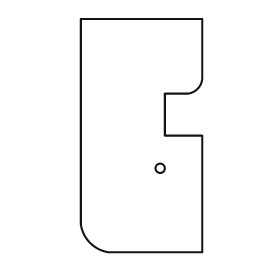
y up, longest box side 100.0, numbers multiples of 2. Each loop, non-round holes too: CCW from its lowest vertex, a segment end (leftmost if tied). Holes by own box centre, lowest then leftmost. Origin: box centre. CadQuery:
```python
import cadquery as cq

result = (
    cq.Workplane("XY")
    .moveTo(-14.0, -50.0)
    .lineTo(26.0, -50.0)
    .lineTo(26.0, 0.0)
    .lineTo(10.0, 0.0)
    .lineTo(10.0, 18.0)
    .lineTo(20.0, 18.0)
    .threePointArc((24.0, 20.0), (26.0, 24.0))
    .lineTo(26.0, 50.0)
    .lineTo(-26.0, 50.0)
    .lineTo(-26.0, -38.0)
    .threePointArc((-22.0, -46.0), (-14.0, -50.0))
    .close()
    .moveTo(8.0, -14.0)
    .circle(2.0)
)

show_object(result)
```